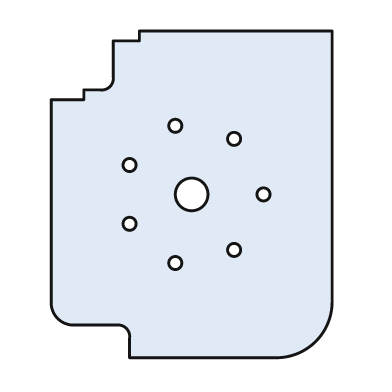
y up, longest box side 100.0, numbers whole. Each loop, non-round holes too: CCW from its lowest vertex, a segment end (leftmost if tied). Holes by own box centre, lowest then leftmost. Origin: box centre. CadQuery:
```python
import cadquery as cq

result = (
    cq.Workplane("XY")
    .moveTo(-19.0, -50.0)
    .lineTo(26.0, -50.0)
    .threePointArc((38.0, -45.0), (43.0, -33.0))
    .lineTo(43.0, 50.0)
    .lineTo(-16.0, 50.0)
    .lineTo(-16.0, 47.0)
    .lineTo(-24.0, 47.0)
    .lineTo(-24.0, 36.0)
    .threePointArc((-25.0, 33.0), (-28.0, 32.0))
    .lineTo(-33.0, 32.0)
    .lineTo(-33.0, 29.0)
    .lineTo(-43.0, 29.0)
    .lineTo(-43.0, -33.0)
    .threePointArc((-41.0, -38.0), (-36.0, -40.0))
    .lineTo(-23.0, -40.0)
    .threePointArc((-20.0, -41.0), (-19.0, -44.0))
    .close()
    .moveTo(-5.0, -21.0)
    .circle(2.0)
    .moveTo(13.0, -17.0)
    .circle(2.0)
    .moveTo(-19.0, -9.0)
    .circle(2.0)
    .moveTo(0.0, 0.0)
    .circle(5.0)
    .moveTo(22.0, 0.0)
    .circle(2.0)
    .moveTo(-19.0, 9.0)
    .circle(2.0)
    .moveTo(13.0, 17.0)
    .circle(2.0)
    .moveTo(-5.0, 21.0)
    .circle(2.0)
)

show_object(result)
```